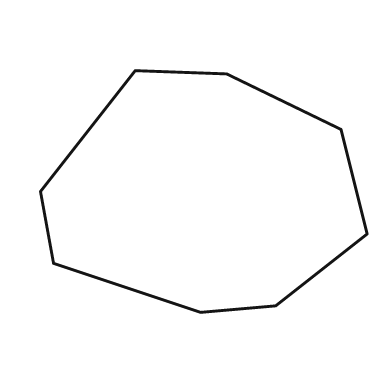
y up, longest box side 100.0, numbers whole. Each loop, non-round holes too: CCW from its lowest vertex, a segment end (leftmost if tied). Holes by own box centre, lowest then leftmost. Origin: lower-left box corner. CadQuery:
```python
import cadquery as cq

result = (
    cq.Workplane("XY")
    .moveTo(49.0, 0.0)
    .lineTo(72.0, 2.0)
    .lineTo(100.0, 24.0)
    .lineTo(92.0, 56.0)
    .lineTo(57.0, 73.0)
    .lineTo(29.0, 74.0)
    .lineTo(0.0, 37.0)
    .lineTo(4.0, 15.0)
    .close()
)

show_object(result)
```